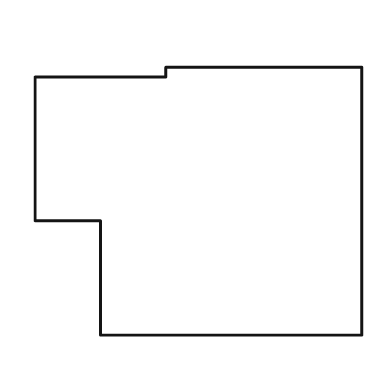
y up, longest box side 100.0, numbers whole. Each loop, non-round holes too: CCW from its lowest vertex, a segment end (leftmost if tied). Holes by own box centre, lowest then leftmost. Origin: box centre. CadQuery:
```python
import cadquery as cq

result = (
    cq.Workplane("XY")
    .moveTo(-30.0, -41.0)
    .lineTo(50.0, -41.0)
    .lineTo(50.0, 41.0)
    .lineTo(-10.0, 41.0)
    .lineTo(-10.0, 38.0)
    .lineTo(-50.0, 38.0)
    .lineTo(-50.0, -6.0)
    .lineTo(-30.0, -6.0)
    .close()
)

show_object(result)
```